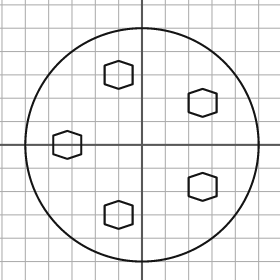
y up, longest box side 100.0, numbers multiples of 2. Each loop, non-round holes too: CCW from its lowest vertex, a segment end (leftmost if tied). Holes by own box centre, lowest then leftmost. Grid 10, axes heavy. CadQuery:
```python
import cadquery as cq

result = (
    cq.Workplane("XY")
    .moveTo(0.0, 0.0)
    .circle(50.0)
    .moveTo(-10.0, -36.0)
    .lineTo(-4.0, -34.0)
    .lineTo(-4.0, -26.0)
    .lineTo(-10.0, -24.0)
    .lineTo(-16.0, -26.0)
    .lineTo(-16.0, -34.0)
    .close()
    .moveTo(26.0, -24.0)
    .lineTo(32.0, -22.0)
    .lineTo(32.0, -14.0)
    .lineTo(26.0, -12.0)
    .lineTo(20.0, -14.0)
    .lineTo(20.0, -22.0)
    .close()
    .moveTo(-32.0, -6.0)
    .lineTo(-26.0, -4.0)
    .lineTo(-26.0, 4.0)
    .lineTo(-32.0, 6.0)
    .lineTo(-38.0, 4.0)
    .lineTo(-38.0, -4.0)
    .close()
    .moveTo(26.0, 12.0)
    .lineTo(32.0, 14.0)
    .lineTo(32.0, 22.0)
    .lineTo(26.0, 24.0)
    .lineTo(20.0, 22.0)
    .lineTo(20.0, 14.0)
    .close()
    .moveTo(-10.0, 24.0)
    .lineTo(-4.0, 26.0)
    .lineTo(-4.0, 34.0)
    .lineTo(-10.0, 36.0)
    .lineTo(-16.0, 34.0)
    .lineTo(-16.0, 26.0)
    .close()
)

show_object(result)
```